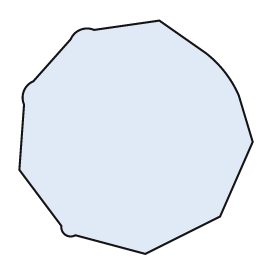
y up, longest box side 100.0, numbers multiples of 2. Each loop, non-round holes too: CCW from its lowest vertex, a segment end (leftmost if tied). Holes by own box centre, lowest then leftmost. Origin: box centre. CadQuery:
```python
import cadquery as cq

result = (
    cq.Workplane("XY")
    .moveTo(4.0, -50.0)
    .lineTo(36.0, -34.0)
    .lineTo(50.0, -2.0)
    .lineTo(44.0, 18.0)
    .threePointArc((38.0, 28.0), (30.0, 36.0))
    .lineTo(10.0, 50.0)
    .lineTo(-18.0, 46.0)
    .threePointArc((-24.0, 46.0), (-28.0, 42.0))
    .lineTo(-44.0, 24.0)
    .threePointArc((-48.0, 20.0), (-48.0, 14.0))
    .lineTo(-50.0, -14.0)
    .lineTo(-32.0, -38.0)
    .threePointArc((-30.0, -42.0), (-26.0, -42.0))
    .close()
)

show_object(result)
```